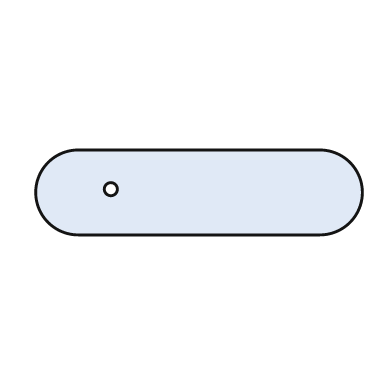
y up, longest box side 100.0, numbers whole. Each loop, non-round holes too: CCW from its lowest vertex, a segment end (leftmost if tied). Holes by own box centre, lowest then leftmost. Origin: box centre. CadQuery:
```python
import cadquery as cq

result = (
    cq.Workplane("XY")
    .moveTo(-37.0, -13.0)
    .lineTo(37.0, -13.0)
    .threePointArc((50.0, 0.0), (37.0, 13.0))
    .lineTo(-37.0, 13.0)
    .threePointArc((-50.0, 0.0), (-37.0, -13.0))
    .close()
    .moveTo(-27.0, 1.0)
    .circle(2.0)
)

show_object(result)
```